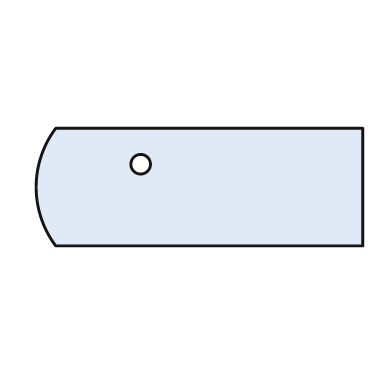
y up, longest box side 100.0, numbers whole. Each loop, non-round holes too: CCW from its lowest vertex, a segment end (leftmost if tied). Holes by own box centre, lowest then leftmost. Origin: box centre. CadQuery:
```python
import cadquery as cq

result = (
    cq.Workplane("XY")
    .moveTo(-44.0, -18.0)
    .lineTo(50.0, -18.0)
    .lineTo(50.0, 18.0)
    .lineTo(-44.0, 18.0)
    .threePointArc((-50.0, 0.0), (-44.0, -18.0))
    .close()
    .moveTo(-18.0, 7.0)
    .circle(3.0)
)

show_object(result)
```